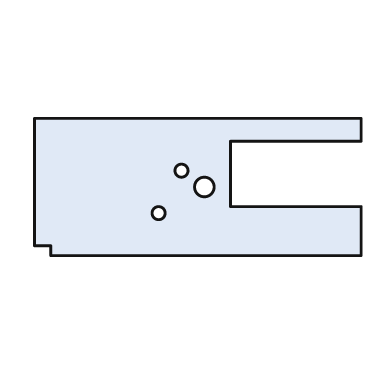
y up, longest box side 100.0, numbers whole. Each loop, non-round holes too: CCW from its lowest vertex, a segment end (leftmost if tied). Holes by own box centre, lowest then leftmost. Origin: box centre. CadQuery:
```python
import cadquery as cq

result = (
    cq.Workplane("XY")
    .moveTo(-45.0, -21.0)
    .lineTo(50.0, -21.0)
    .lineTo(50.0, -6.0)
    .lineTo(10.0, -6.0)
    .lineTo(10.0, 14.0)
    .lineTo(50.0, 14.0)
    .lineTo(50.0, 21.0)
    .lineTo(-50.0, 21.0)
    .lineTo(-50.0, -18.0)
    .lineTo(-45.0, -18.0)
    .close()
    .moveTo(-12.0, -8.0)
    .circle(2.0)
    .moveTo(2.0, 0.0)
    .circle(3.0)
    .moveTo(-5.0, 5.0)
    .circle(2.0)
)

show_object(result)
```